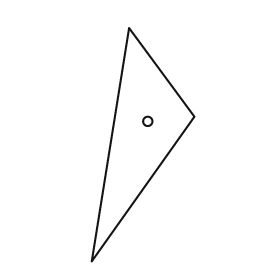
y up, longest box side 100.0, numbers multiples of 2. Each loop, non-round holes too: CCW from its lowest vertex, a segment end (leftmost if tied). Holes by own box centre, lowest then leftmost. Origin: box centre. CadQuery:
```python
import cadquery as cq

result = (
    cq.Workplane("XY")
    .moveTo(-22.0, -50.0)
    .lineTo(22.0, 12.0)
    .lineTo(-6.0, 50.0)
    .close()
    .moveTo(2.0, 10.0)
    .circle(2.0)
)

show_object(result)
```